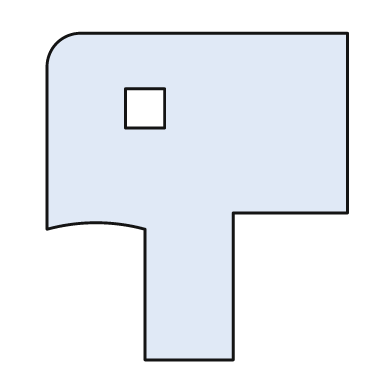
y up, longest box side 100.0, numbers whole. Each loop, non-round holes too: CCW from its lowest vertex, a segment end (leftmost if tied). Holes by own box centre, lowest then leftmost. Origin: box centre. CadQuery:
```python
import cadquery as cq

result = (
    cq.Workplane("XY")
    .moveTo(-16.0, -50.0)
    .lineTo(11.0, -50.0)
    .lineTo(11.0, -5.0)
    .lineTo(46.0, -5.0)
    .lineTo(46.0, 50.0)
    .lineTo(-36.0, 50.0)
    .threePointArc((-43.0, 47.0), (-46.0, 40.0))
    .lineTo(-46.0, -10.0)
    .threePointArc((-31.0, -8.0), (-16.0, -10.0))
    .close()
    .moveTo(-22.0, 21.0)
    .lineTo(-10.0, 21.0)
    .lineTo(-10.0, 33.0)
    .lineTo(-22.0, 33.0)
    .close()
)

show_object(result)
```